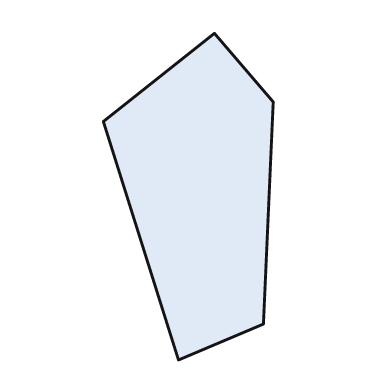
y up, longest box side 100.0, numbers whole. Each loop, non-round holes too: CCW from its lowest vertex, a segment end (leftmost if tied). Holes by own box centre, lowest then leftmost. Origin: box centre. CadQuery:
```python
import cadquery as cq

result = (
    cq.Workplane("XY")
    .moveTo(-3.0, -50.0)
    .lineTo(23.0, -39.0)
    .lineTo(26.0, 29.0)
    .lineTo(8.0, 50.0)
    .lineTo(-26.0, 23.0)
    .close()
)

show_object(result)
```